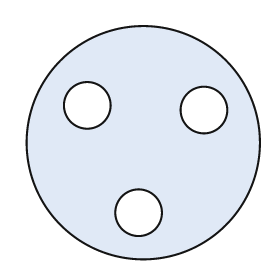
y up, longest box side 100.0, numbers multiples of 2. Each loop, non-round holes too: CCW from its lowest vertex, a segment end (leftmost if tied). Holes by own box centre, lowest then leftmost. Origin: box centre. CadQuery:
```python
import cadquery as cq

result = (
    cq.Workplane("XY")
    .moveTo(0.0, 0.0)
    .circle(50.0)
    .moveTo(-2.0, -30.0)
    .circle(10.0)
    .moveTo(26.0, 14.0)
    .circle(10.0)
    .moveTo(-24.0, 16.0)
    .circle(10.0)
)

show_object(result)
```